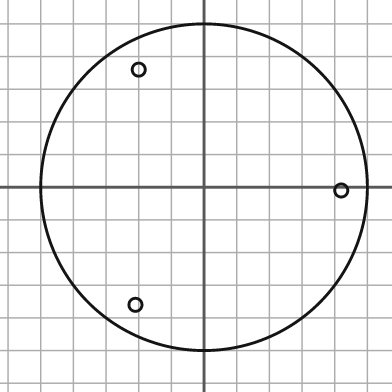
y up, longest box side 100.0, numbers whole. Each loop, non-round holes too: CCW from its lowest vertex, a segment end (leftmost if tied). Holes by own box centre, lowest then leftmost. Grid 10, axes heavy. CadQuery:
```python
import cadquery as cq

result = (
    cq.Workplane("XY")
    .moveTo(0.0, 0.0)
    .circle(50.0)
    .moveTo(-21.0, -36.0)
    .circle(2.0)
    .moveTo(42.0, -1.0)
    .circle(2.0)
    .moveTo(-20.0, 36.0)
    .circle(2.0)
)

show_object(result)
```